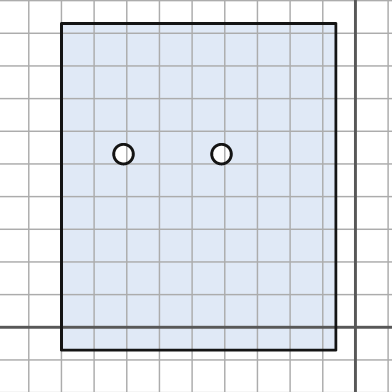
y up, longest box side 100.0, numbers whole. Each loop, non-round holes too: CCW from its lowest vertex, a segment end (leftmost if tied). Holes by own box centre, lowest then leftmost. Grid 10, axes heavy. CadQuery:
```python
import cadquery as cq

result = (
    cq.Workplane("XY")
    .moveTo(-90.0, -7.0)
    .lineTo(-6.0, -7.0)
    .lineTo(-6.0, 93.0)
    .lineTo(-90.0, 93.0)
    .close()
    .moveTo(-71.0, 53.0)
    .circle(3.0)
    .moveTo(-41.0, 53.0)
    .circle(3.0)
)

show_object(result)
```